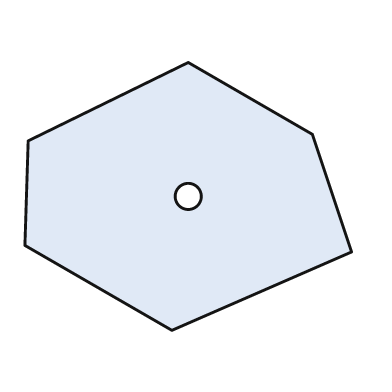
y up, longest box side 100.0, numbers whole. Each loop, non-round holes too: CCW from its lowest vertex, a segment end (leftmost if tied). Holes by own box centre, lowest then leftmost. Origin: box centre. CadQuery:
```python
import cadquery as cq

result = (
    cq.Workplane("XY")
    .moveTo(-5.0, -41.0)
    .lineTo(50.0, -17.0)
    .lineTo(38.0, 19.0)
    .lineTo(0.0, 41.0)
    .lineTo(-49.0, 17.0)
    .lineTo(-50.0, -15.0)
    .close()
    .moveTo(0.0, 0.0)
    .circle(4.0)
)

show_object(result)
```